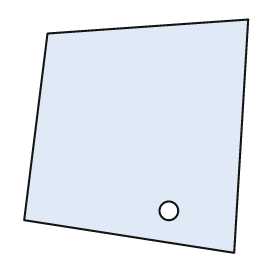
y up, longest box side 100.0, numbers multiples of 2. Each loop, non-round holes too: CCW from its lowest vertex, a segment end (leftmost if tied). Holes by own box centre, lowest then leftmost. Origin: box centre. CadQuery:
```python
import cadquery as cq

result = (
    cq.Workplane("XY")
    .moveTo(42.0, -50.0)
    .lineTo(48.0, 50.0)
    .lineTo(-38.0, 44.0)
    .lineTo(-48.0, -36.0)
    .close()
    .moveTo(14.0, -32.0)
    .circle(4.0)
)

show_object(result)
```